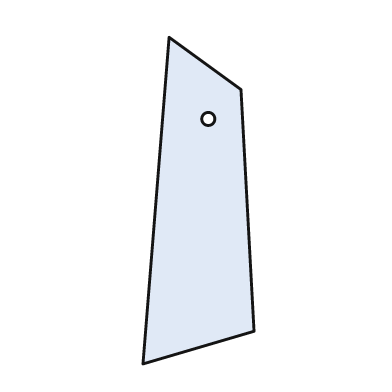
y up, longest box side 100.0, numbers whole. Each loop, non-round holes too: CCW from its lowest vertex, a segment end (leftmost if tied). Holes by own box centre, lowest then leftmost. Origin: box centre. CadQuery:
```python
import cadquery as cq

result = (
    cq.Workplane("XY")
    .moveTo(-17.0, -50.0)
    .lineTo(17.0, -40.0)
    .lineTo(13.0, 34.0)
    .lineTo(-9.0, 50.0)
    .close()
    .moveTo(3.0, 25.0)
    .circle(2.0)
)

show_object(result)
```